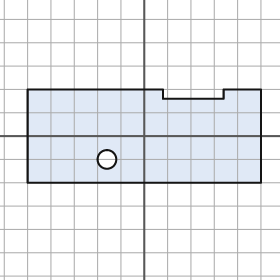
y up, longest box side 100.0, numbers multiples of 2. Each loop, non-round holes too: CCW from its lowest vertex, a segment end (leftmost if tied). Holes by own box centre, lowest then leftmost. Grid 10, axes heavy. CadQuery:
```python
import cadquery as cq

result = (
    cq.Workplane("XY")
    .moveTo(-50.0, -20.0)
    .lineTo(50.0, -20.0)
    .lineTo(50.0, 20.0)
    .lineTo(34.0, 20.0)
    .lineTo(34.0, 16.0)
    .lineTo(8.0, 16.0)
    .lineTo(8.0, 20.0)
    .lineTo(-50.0, 20.0)
    .close()
    .moveTo(-16.0, -10.0)
    .circle(4.0)
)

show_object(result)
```